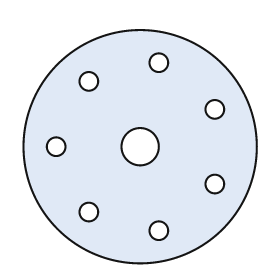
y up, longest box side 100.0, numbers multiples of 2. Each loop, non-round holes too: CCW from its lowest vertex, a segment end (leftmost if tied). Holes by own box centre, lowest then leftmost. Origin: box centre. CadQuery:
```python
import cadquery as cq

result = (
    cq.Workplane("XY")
    .moveTo(0.0, 0.0)
    .circle(50.0)
    .moveTo(8.0, -36.0)
    .circle(4.0)
    .moveTo(-22.0, -28.0)
    .circle(4.0)
    .moveTo(32.0, -16.0)
    .circle(4.0)
    .moveTo(-36.0, 0.0)
    .circle(4.0)
    .moveTo(0.0, 0.0)
    .circle(8.0)
    .moveTo(32.0, 16.0)
    .circle(4.0)
    .moveTo(-22.0, 28.0)
    .circle(4.0)
    .moveTo(8.0, 36.0)
    .circle(4.0)
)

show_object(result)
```